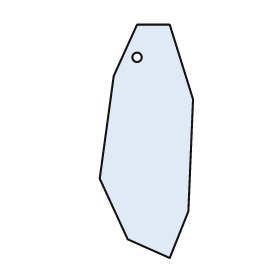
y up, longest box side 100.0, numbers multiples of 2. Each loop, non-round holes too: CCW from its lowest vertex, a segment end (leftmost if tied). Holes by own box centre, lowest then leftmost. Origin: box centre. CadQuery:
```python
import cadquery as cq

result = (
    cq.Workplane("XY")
    .moveTo(10.0, -50.0)
    .lineTo(18.0, -30.0)
    .lineTo(20.0, 18.0)
    .lineTo(10.0, 50.0)
    .lineTo(-4.0, 50.0)
    .lineTo(-14.0, 28.0)
    .lineTo(-20.0, -16.0)
    .lineTo(-8.0, -42.0)
    .close()
    .moveTo(-4.0, 36.0)
    .circle(2.0)
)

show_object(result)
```